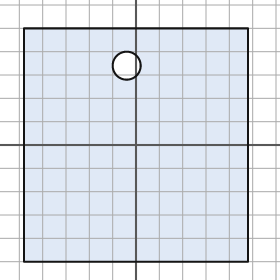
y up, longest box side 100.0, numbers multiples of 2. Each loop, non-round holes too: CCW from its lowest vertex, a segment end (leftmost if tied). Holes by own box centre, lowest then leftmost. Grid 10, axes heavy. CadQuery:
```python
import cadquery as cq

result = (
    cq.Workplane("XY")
    .moveTo(-48.0, -50.0)
    .lineTo(48.0, -50.0)
    .lineTo(48.0, 50.0)
    .lineTo(-48.0, 50.0)
    .close()
    .moveTo(-4.0, 34.0)
    .circle(6.0)
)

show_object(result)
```